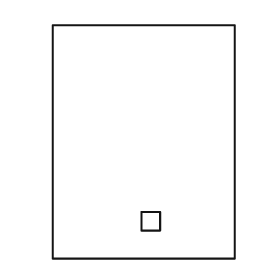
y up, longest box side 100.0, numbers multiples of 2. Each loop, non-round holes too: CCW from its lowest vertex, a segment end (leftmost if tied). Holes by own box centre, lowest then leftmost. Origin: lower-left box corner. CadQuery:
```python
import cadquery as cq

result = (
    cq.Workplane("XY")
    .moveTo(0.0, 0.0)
    .lineTo(78.0, 0.0)
    .lineTo(78.0, 100.0)
    .lineTo(0.0, 100.0)
    .close()
    .moveTo(38.0, 12.0)
    .lineTo(46.0, 12.0)
    .lineTo(46.0, 20.0)
    .lineTo(38.0, 20.0)
    .close()
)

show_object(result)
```